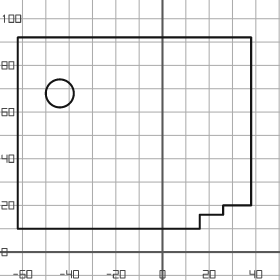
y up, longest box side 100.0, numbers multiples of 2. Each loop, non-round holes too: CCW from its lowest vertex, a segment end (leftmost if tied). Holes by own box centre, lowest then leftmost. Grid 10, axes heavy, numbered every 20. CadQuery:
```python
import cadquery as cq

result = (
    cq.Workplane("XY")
    .moveTo(-62.0, 10.0)
    .lineTo(16.0, 10.0)
    .lineTo(16.0, 16.0)
    .lineTo(26.0, 16.0)
    .lineTo(26.0, 20.0)
    .lineTo(38.0, 20.0)
    .lineTo(38.0, 92.0)
    .lineTo(-62.0, 92.0)
    .close()
    .moveTo(-44.0, 68.0)
    .circle(6.0)
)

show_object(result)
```